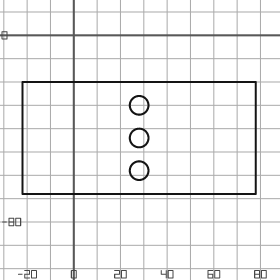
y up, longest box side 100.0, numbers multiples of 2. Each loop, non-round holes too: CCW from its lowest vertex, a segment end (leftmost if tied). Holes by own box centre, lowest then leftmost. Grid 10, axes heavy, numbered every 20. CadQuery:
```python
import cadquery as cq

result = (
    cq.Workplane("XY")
    .moveTo(-22.0, -68.0)
    .lineTo(78.0, -68.0)
    .lineTo(78.0, -20.0)
    .lineTo(-22.0, -20.0)
    .close()
    .moveTo(28.0, -58.0)
    .circle(4.0)
    .moveTo(28.0, -44.0)
    .circle(4.0)
    .moveTo(28.0, -30.0)
    .circle(4.0)
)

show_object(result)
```